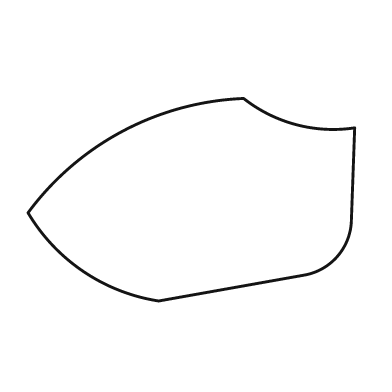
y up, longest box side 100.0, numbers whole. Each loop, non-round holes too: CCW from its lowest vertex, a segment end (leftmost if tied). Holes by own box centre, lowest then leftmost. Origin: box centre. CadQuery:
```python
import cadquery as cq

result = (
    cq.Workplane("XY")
    .moveTo(-10.0, -31.0)
    .lineTo(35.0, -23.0)
    .threePointArc((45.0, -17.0), (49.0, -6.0))
    .lineTo(50.0, 22.0)
    .threePointArc((32.0, 23.0), (16.0, 31.0))
    .threePointArc((-21.0, 21.0), (-50.0, -4.0))
    .threePointArc((-33.0, -22.0), (-10.0, -31.0))
    .close()
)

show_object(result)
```